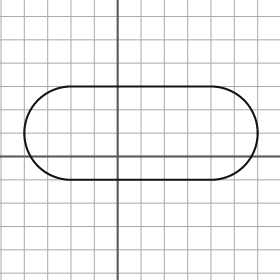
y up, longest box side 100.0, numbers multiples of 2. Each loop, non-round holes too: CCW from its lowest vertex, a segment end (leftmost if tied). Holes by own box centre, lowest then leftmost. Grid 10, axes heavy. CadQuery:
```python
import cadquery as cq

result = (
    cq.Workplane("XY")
    .moveTo(-20.0, -10.0)
    .lineTo(40.0, -10.0)
    .threePointArc((60.0, 10.0), (40.0, 30.0))
    .lineTo(-20.0, 30.0)
    .threePointArc((-40.0, 10.0), (-20.0, -10.0))
    .close()
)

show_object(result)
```